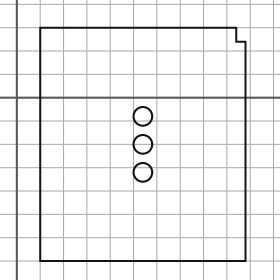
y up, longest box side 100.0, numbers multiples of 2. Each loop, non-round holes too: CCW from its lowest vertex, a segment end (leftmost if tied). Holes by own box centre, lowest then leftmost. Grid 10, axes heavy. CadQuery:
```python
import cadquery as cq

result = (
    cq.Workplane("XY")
    .moveTo(10.0, -70.0)
    .lineTo(98.0, -70.0)
    .lineTo(98.0, 24.0)
    .lineTo(94.0, 24.0)
    .lineTo(94.0, 30.0)
    .lineTo(10.0, 30.0)
    .close()
    .moveTo(54.0, -32.0)
    .circle(4.0)
    .moveTo(54.0, -20.0)
    .circle(4.0)
    .moveTo(54.0, -8.0)
    .circle(4.0)
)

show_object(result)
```